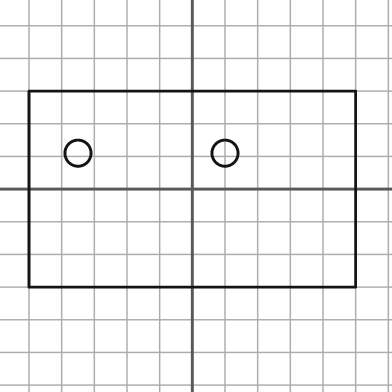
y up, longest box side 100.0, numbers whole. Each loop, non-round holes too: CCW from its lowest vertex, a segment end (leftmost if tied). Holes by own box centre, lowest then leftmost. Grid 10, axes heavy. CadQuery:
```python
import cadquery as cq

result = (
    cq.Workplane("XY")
    .moveTo(-50.0, -30.0)
    .lineTo(50.0, -30.0)
    .lineTo(50.0, 30.0)
    .lineTo(-50.0, 30.0)
    .close()
    .moveTo(-35.0, 11.0)
    .circle(4.0)
    .moveTo(10.0, 11.0)
    .circle(4.0)
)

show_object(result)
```